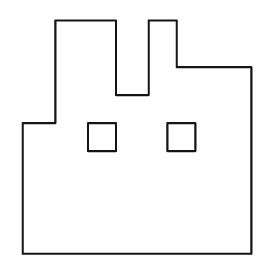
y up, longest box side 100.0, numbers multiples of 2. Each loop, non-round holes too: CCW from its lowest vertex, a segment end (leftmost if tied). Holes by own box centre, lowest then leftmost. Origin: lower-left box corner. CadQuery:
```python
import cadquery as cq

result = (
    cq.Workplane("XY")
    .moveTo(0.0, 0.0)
    .lineTo(98.0, 0.0)
    .lineTo(98.0, 80.0)
    .lineTo(66.0, 80.0)
    .lineTo(66.0, 100.0)
    .lineTo(54.0, 100.0)
    .lineTo(54.0, 68.0)
    .lineTo(40.0, 68.0)
    .lineTo(40.0, 100.0)
    .lineTo(14.0, 100.0)
    .lineTo(14.0, 56.0)
    .lineTo(0.0, 56.0)
    .close()
    .moveTo(28.0, 44.0)
    .lineTo(40.0, 44.0)
    .lineTo(40.0, 56.0)
    .lineTo(28.0, 56.0)
    .close()
    .moveTo(62.0, 44.0)
    .lineTo(74.0, 44.0)
    .lineTo(74.0, 56.0)
    .lineTo(62.0, 56.0)
    .close()
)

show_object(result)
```